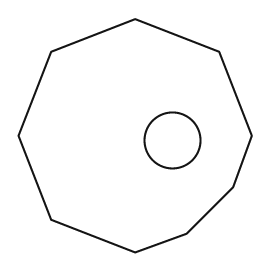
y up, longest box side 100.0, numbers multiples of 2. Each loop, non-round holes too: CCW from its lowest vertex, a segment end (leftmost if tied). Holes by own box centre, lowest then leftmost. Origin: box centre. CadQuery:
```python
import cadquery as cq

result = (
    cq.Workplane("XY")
    .moveTo(0.0, -50.0)
    .lineTo(22.0, -42.0)
    .lineTo(42.0, -22.0)
    .lineTo(50.0, 0.0)
    .lineTo(36.0, 36.0)
    .lineTo(0.0, 50.0)
    .lineTo(-36.0, 36.0)
    .lineTo(-50.0, 0.0)
    .lineTo(-36.0, -36.0)
    .close()
    .moveTo(16.0, -2.0)
    .circle(12.0)
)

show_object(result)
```